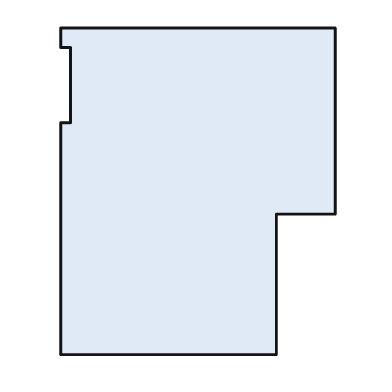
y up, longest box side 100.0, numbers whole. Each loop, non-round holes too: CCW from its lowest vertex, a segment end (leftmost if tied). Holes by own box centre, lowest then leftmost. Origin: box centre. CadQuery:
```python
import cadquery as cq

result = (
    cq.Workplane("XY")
    .moveTo(-42.0, -50.0)
    .lineTo(24.0, -50.0)
    .lineTo(24.0, -7.0)
    .lineTo(42.0, -7.0)
    .lineTo(42.0, 50.0)
    .lineTo(-42.0, 50.0)
    .lineTo(-42.0, 44.0)
    .lineTo(-39.0, 44.0)
    .lineTo(-39.0, 21.0)
    .lineTo(-42.0, 21.0)
    .close()
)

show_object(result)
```